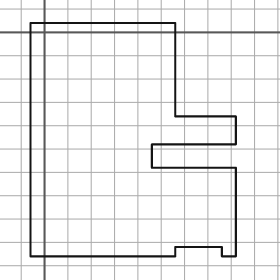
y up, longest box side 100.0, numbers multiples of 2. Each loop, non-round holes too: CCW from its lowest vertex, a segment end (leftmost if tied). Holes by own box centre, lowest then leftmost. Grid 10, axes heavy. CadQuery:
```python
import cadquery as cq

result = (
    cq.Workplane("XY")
    .moveTo(-6.0, -96.0)
    .lineTo(56.0, -96.0)
    .lineTo(56.0, -92.0)
    .lineTo(76.0, -92.0)
    .lineTo(76.0, -96.0)
    .lineTo(82.0, -96.0)
    .lineTo(82.0, -58.0)
    .lineTo(46.0, -58.0)
    .lineTo(46.0, -48.0)
    .lineTo(82.0, -48.0)
    .lineTo(82.0, -36.0)
    .lineTo(56.0, -36.0)
    .lineTo(56.0, 4.0)
    .lineTo(-6.0, 4.0)
    .close()
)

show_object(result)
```